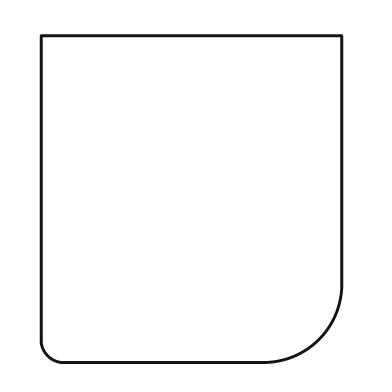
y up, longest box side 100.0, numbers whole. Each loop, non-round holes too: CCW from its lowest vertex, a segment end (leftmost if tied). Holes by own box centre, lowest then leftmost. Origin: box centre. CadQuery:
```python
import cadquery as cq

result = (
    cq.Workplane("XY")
    .moveTo(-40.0, -50.0)
    .lineTo(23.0, -50.0)
    .threePointArc((39.0, -43.0), (46.0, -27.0))
    .lineTo(46.0, 50.0)
    .lineTo(-46.0, 50.0)
    .lineTo(-46.0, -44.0)
    .threePointArc((-44.0, -48.0), (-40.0, -50.0))
    .close()
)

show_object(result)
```